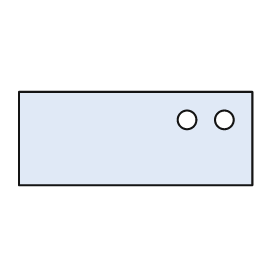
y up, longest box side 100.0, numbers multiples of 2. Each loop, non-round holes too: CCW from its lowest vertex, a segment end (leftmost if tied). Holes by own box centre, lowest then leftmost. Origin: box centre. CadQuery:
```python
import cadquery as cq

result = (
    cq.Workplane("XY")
    .moveTo(-50.0, -20.0)
    .lineTo(50.0, -20.0)
    .lineTo(50.0, 20.0)
    .lineTo(-50.0, 20.0)
    .close()
    .moveTo(22.0, 8.0)
    .circle(4.0)
    .moveTo(38.0, 8.0)
    .circle(4.0)
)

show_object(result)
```